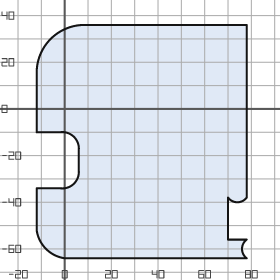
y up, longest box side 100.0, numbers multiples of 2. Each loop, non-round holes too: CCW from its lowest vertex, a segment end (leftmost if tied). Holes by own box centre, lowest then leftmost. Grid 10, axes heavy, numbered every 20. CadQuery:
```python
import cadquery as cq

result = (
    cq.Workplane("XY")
    .moveTo(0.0, -64.0)
    .lineTo(78.0, -64.0)
    .threePointArc((76.0, -60.0), (78.0, -56.0))
    .lineTo(70.0, -56.0)
    .lineTo(70.0, -38.0)
    .threePointArc((74.0, -40.0), (78.0, -38.0))
    .lineTo(78.0, 36.0)
    .lineTo(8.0, 36.0)
    .threePointArc((-6.0, 30.0), (-12.0, 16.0))
    .lineTo(-12.0, -10.0)
    .lineTo(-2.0, -10.0)
    .threePointArc((4.0, -12.0), (6.0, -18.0))
    .lineTo(6.0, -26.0)
    .threePointArc((4.0, -32.0), (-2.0, -34.0))
    .lineTo(-12.0, -34.0)
    .lineTo(-12.0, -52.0)
    .threePointArc((-8.0, -60.0), (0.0, -64.0))
    .close()
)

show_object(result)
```